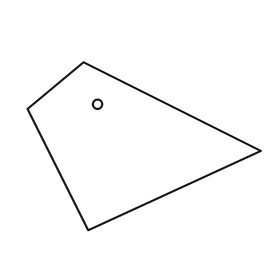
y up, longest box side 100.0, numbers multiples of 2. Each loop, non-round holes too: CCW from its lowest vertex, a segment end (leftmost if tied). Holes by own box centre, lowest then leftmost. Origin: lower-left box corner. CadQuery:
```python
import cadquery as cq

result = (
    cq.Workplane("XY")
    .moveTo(26.0, 0.0)
    .lineTo(100.0, 34.0)
    .lineTo(24.0, 72.0)
    .lineTo(0.0, 52.0)
    .close()
    .moveTo(30.0, 54.0)
    .circle(2.0)
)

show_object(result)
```